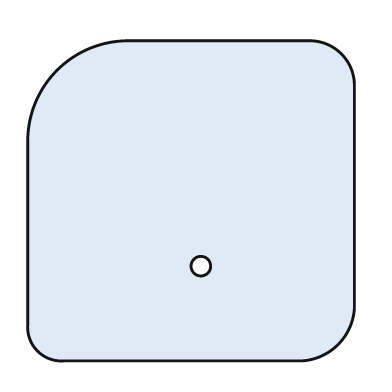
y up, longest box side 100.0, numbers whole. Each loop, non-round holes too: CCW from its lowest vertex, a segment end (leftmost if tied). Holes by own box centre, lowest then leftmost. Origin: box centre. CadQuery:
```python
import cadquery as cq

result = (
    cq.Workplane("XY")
    .moveTo(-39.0, -49.0)
    .lineTo(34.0, -49.0)
    .threePointArc((45.0, -44.0), (50.0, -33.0))
    .lineTo(50.0, 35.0)
    .threePointArc((46.0, 45.0), (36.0, 49.0))
    .lineTo(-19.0, 49.0)
    .threePointArc((-41.0, 40.0), (-50.0, 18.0))
    .lineTo(-50.0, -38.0)
    .threePointArc((-47.0, -46.0), (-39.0, -49.0))
    .close()
    .moveTo(3.0, -20.0)
    .circle(3.0)
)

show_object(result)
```